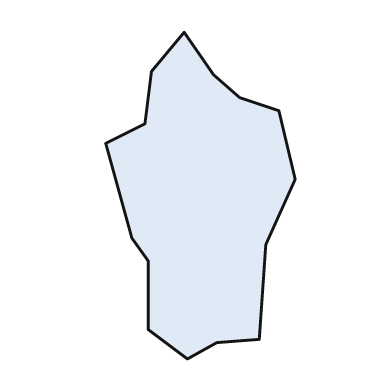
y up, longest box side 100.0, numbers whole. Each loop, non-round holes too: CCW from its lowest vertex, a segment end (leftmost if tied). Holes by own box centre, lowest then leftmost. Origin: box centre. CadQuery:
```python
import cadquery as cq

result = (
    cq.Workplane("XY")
    .moveTo(-4.0, -50.0)
    .lineTo(5.0, -45.0)
    .lineTo(18.0, -44.0)
    .lineTo(20.0, -15.0)
    .lineTo(29.0, 5.0)
    .lineTo(24.0, 26.0)
    .lineTo(12.0, 30.0)
    .lineTo(4.0, 37.0)
    .lineTo(-5.0, 50.0)
    .lineTo(-15.0, 38.0)
    .lineTo(-17.0, 22.0)
    .lineTo(-29.0, 16.0)
    .lineTo(-21.0, -13.0)
    .lineTo(-16.0, -20.0)
    .lineTo(-16.0, -41.0)
    .close()
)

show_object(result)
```